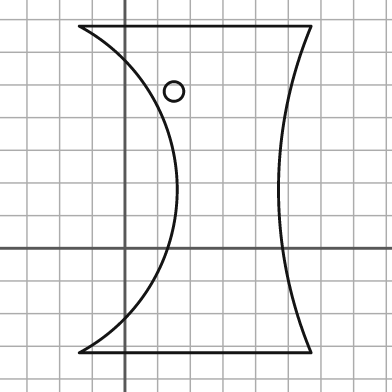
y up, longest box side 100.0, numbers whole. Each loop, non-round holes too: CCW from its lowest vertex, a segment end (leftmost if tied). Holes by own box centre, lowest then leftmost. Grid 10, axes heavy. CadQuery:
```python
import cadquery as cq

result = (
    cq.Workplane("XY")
    .moveTo(-14.0, -32.0)
    .lineTo(57.0, -32.0)
    .threePointArc((47.0, 18.0), (57.0, 68.0))
    .lineTo(-14.0, 68.0)
    .threePointArc((16.0, 18.0), (-14.0, -32.0))
    .close()
    .moveTo(15.0, 48.0)
    .circle(3.0)
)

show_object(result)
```